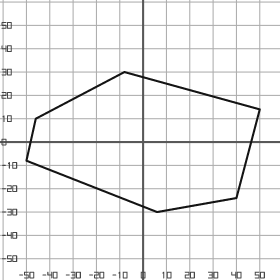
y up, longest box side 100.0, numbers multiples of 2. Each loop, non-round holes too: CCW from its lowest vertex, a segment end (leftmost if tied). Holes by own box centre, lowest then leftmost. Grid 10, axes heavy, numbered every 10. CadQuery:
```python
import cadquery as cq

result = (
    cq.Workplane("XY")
    .moveTo(6.0, -30.0)
    .lineTo(40.0, -24.0)
    .lineTo(50.0, 14.0)
    .lineTo(-8.0, 30.0)
    .lineTo(-46.0, 10.0)
    .lineTo(-50.0, -8.0)
    .close()
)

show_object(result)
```